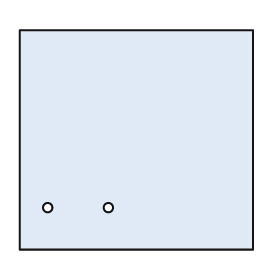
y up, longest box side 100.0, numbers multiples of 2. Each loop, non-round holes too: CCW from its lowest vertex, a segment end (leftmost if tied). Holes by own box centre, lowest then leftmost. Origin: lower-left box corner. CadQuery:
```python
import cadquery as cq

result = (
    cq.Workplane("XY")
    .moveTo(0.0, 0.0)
    .lineTo(100.0, 0.0)
    .lineTo(100.0, 94.0)
    .lineTo(0.0, 94.0)
    .close()
    .moveTo(12.0, 18.0)
    .circle(2.0)
    .moveTo(38.0, 18.0)
    .circle(2.0)
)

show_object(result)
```